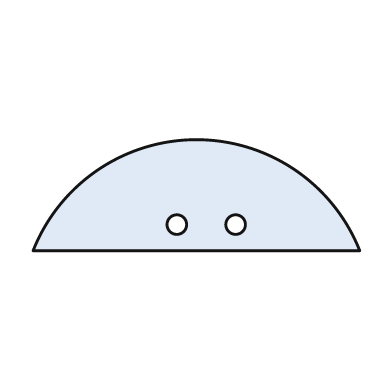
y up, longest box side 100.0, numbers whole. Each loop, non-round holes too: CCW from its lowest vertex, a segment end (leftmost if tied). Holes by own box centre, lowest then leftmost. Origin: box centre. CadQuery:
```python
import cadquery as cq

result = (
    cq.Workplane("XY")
    .moveTo(-50.0, -17.0)
    .lineTo(50.0, -17.0)
    .threePointArc((0.0, 17.0), (-50.0, -17.0))
    .close()
    .moveTo(-6.0, -9.0)
    .circle(3.0)
    .moveTo(12.0, -9.0)
    .circle(3.0)
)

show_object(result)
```